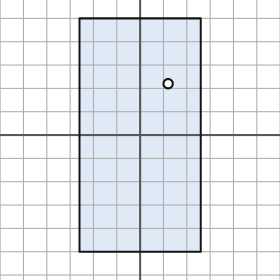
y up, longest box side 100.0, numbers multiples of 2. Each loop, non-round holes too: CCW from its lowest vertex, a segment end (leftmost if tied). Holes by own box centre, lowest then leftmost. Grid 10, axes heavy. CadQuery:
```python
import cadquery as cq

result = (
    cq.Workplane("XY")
    .moveTo(-26.0, -50.0)
    .lineTo(26.0, -50.0)
    .lineTo(26.0, 50.0)
    .lineTo(-26.0, 50.0)
    .close()
    .moveTo(12.0, 22.0)
    .circle(2.0)
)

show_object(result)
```